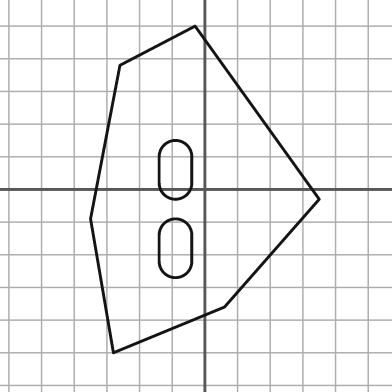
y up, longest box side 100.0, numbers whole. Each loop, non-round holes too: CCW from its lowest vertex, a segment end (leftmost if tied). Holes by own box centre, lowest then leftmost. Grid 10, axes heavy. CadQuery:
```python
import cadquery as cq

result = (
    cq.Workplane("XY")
    .moveTo(-28.0, -50.0)
    .lineTo(6.0, -36.0)
    .lineTo(35.0, -3.0)
    .lineTo(-3.0, 50.0)
    .lineTo(-26.0, 38.0)
    .lineTo(-35.0, -9.0)
    .close()
    .moveTo(-14.0, -22.0)
    .threePointArc((-9.0, -27.0), (-4.0, -22.0))
    .lineTo(-4.0, -14.0)
    .threePointArc((-9.0, -9.0), (-14.0, -14.0))
    .close()
    .moveTo(-14.0, 2.0)
    .threePointArc((-9.0, -3.0), (-4.0, 2.0))
    .lineTo(-4.0, 10.0)
    .threePointArc((-9.0, 15.0), (-14.0, 10.0))
    .close()
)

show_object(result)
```